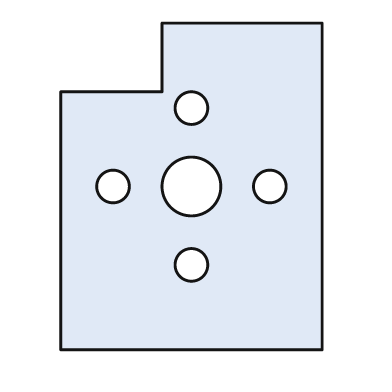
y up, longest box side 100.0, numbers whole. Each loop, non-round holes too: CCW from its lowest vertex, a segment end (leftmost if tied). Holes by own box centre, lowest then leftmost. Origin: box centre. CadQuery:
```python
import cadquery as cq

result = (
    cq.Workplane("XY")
    .moveTo(-40.0, -50.0)
    .lineTo(40.0, -50.0)
    .lineTo(40.0, 50.0)
    .lineTo(-9.0, 50.0)
    .lineTo(-9.0, 29.0)
    .lineTo(-40.0, 29.0)
    .close()
    .moveTo(0.0, -24.0)
    .circle(5.0)
    .moveTo(-24.0, 0.0)
    .circle(5.0)
    .moveTo(0.0, 0.0)
    .circle(9.0)
    .moveTo(24.0, 0.0)
    .circle(5.0)
    .moveTo(0.0, 24.0)
    .circle(5.0)
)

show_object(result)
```